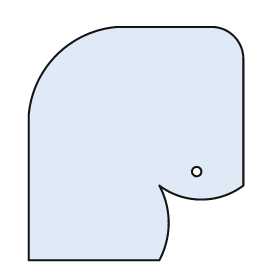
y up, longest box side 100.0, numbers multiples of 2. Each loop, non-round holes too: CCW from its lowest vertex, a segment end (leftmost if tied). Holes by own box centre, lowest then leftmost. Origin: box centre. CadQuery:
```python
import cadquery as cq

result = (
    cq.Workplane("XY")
    .moveTo(-46.0, -50.0)
    .lineTo(10.0, -50.0)
    .threePointArc((14.0, -34.0), (10.0, -18.0))
    .threePointArc((28.0, -24.0), (46.0, -18.0))
    .lineTo(46.0, 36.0)
    .threePointArc((42.0, 46.0), (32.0, 50.0))
    .lineTo(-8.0, 50.0)
    .threePointArc((-34.0, 38.0), (-46.0, 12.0))
    .close()
    .moveTo(26.0, -12.0)
    .circle(2.0)
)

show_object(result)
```